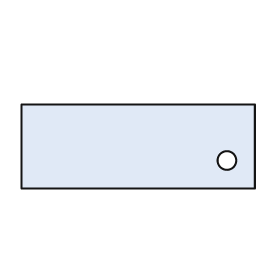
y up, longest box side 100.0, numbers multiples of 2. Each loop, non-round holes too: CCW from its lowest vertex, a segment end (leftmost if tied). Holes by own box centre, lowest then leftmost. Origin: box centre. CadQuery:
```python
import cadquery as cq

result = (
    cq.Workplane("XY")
    .moveTo(-50.0, -18.0)
    .lineTo(50.0, -18.0)
    .lineTo(50.0, 18.0)
    .lineTo(-50.0, 18.0)
    .close()
    .moveTo(38.0, -6.0)
    .circle(4.0)
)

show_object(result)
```